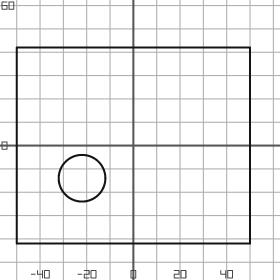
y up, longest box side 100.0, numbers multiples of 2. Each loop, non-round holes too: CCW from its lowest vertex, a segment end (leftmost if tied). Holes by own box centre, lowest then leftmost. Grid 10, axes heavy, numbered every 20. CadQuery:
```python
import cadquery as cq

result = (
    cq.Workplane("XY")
    .moveTo(-50.0, -42.0)
    .lineTo(50.0, -42.0)
    .lineTo(50.0, 42.0)
    .lineTo(-50.0, 42.0)
    .close()
    .moveTo(-22.0, -14.0)
    .circle(10.0)
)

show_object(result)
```